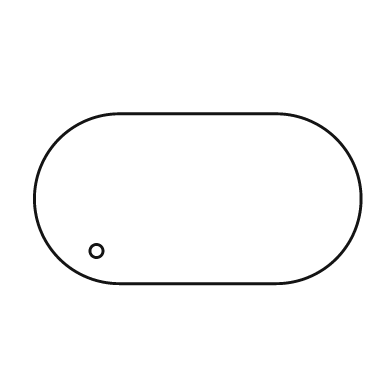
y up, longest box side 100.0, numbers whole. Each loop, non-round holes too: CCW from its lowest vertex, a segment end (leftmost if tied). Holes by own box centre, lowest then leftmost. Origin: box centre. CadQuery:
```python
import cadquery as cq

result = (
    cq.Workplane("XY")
    .moveTo(-24.0, -26.0)
    .lineTo(24.0, -26.0)
    .threePointArc((50.0, 0.0), (24.0, 26.0))
    .lineTo(-24.0, 26.0)
    .threePointArc((-50.0, 0.0), (-24.0, -26.0))
    .close()
    .moveTo(-31.0, -16.0)
    .circle(2.0)
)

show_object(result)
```